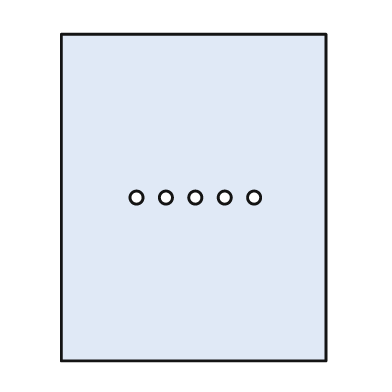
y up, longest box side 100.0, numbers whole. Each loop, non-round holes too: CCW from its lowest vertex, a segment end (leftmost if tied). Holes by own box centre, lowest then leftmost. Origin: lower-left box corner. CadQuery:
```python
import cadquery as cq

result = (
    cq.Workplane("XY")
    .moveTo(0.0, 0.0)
    .lineTo(81.0, 0.0)
    .lineTo(81.0, 100.0)
    .lineTo(0.0, 100.0)
    .close()
    .moveTo(23.0, 50.0)
    .circle(2.0)
    .moveTo(32.0, 50.0)
    .circle(2.0)
    .moveTo(41.0, 50.0)
    .circle(2.0)
    .moveTo(50.0, 50.0)
    .circle(2.0)
    .moveTo(59.0, 50.0)
    .circle(2.0)
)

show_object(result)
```